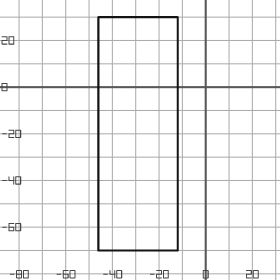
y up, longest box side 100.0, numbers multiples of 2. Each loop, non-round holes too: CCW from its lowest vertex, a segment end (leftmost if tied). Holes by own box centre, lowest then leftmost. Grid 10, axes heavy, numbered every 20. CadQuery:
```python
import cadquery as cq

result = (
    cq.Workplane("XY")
    .moveTo(-46.0, -70.0)
    .lineTo(-12.0, -70.0)
    .lineTo(-12.0, 30.0)
    .lineTo(-46.0, 30.0)
    .close()
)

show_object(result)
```